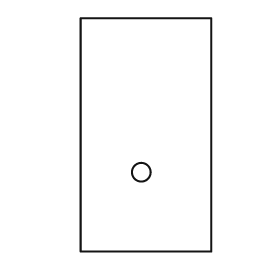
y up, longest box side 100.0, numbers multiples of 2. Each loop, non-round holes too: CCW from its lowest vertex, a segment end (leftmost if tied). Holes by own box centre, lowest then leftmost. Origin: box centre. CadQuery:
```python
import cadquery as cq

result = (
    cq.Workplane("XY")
    .moveTo(-28.0, -50.0)
    .lineTo(28.0, -50.0)
    .lineTo(28.0, 50.0)
    .lineTo(-28.0, 50.0)
    .close()
    .moveTo(-2.0, -16.0)
    .circle(4.0)
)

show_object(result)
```